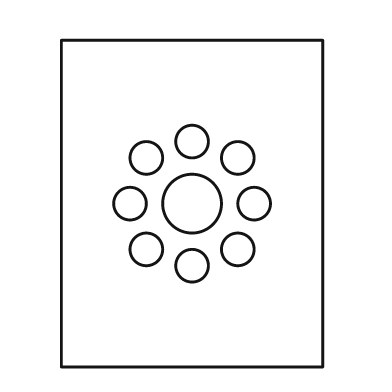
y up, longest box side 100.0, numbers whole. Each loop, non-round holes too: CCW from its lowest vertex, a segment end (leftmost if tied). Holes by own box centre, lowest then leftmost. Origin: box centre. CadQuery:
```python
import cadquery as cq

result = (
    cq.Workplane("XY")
    .moveTo(-40.0, -50.0)
    .lineTo(40.0, -50.0)
    .lineTo(40.0, 50.0)
    .lineTo(-40.0, 50.0)
    .close()
    .moveTo(0.0, -19.0)
    .circle(5.0)
    .moveTo(-14.0, -14.0)
    .circle(5.0)
    .moveTo(14.0, -14.0)
    .circle(5.0)
    .moveTo(-19.0, 0.0)
    .circle(5.0)
    .moveTo(0.0, 0.0)
    .circle(9.0)
    .moveTo(19.0, 0.0)
    .circle(5.0)
    .moveTo(-14.0, 14.0)
    .circle(5.0)
    .moveTo(14.0, 14.0)
    .circle(5.0)
    .moveTo(0.0, 19.0)
    .circle(5.0)
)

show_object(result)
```